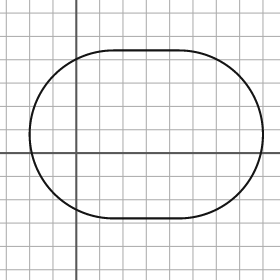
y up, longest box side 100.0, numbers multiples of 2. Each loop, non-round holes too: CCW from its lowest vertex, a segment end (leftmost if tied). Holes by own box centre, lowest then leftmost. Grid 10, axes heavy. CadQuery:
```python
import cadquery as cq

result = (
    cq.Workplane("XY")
    .moveTo(16.0, -28.0)
    .lineTo(44.0, -28.0)
    .threePointArc((80.0, 8.0), (44.0, 44.0))
    .lineTo(16.0, 44.0)
    .threePointArc((-20.0, 8.0), (16.0, -28.0))
    .close()
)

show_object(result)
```